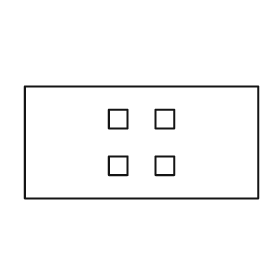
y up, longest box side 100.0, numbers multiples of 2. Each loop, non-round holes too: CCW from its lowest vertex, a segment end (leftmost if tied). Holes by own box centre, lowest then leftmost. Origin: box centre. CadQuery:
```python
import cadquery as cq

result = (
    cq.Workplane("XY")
    .moveTo(-50.0, -24.0)
    .lineTo(50.0, -24.0)
    .lineTo(50.0, 24.0)
    .lineTo(-50.0, 24.0)
    .close()
    .moveTo(-14.0, -14.0)
    .lineTo(-6.0, -14.0)
    .lineTo(-6.0, -6.0)
    .lineTo(-14.0, -6.0)
    .close()
    .moveTo(6.0, -14.0)
    .lineTo(14.0, -14.0)
    .lineTo(14.0, -6.0)
    .lineTo(6.0, -6.0)
    .close()
    .moveTo(-14.0, 6.0)
    .lineTo(-6.0, 6.0)
    .lineTo(-6.0, 14.0)
    .lineTo(-14.0, 14.0)
    .close()
    .moveTo(6.0, 6.0)
    .lineTo(14.0, 6.0)
    .lineTo(14.0, 14.0)
    .lineTo(6.0, 14.0)
    .close()
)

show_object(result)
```